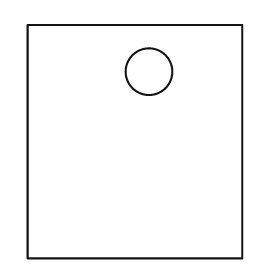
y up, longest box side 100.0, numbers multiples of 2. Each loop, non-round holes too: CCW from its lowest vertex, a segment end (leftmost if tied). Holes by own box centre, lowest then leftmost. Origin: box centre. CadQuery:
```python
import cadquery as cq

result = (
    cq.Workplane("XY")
    .moveTo(-46.0, -50.0)
    .lineTo(46.0, -50.0)
    .lineTo(46.0, 50.0)
    .lineTo(-46.0, 50.0)
    .close()
    .moveTo(6.0, 30.0)
    .circle(10.0)
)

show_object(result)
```